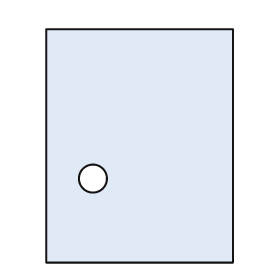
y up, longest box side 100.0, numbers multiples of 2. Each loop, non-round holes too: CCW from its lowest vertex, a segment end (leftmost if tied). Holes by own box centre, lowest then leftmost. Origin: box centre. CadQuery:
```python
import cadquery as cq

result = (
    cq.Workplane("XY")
    .moveTo(-40.0, -50.0)
    .lineTo(40.0, -50.0)
    .lineTo(40.0, 50.0)
    .lineTo(-40.0, 50.0)
    .close()
    .moveTo(-20.0, -14.0)
    .circle(6.0)
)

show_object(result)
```